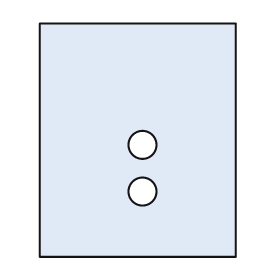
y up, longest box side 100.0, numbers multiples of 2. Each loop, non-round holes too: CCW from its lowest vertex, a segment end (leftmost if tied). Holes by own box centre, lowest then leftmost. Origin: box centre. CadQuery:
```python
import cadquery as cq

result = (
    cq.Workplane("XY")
    .moveTo(-42.0, -50.0)
    .lineTo(42.0, -50.0)
    .lineTo(42.0, 50.0)
    .lineTo(-42.0, 50.0)
    .close()
    .moveTo(2.0, -22.0)
    .circle(6.0)
    .moveTo(2.0, -2.0)
    .circle(6.0)
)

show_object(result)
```